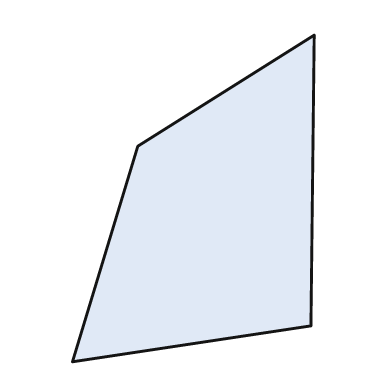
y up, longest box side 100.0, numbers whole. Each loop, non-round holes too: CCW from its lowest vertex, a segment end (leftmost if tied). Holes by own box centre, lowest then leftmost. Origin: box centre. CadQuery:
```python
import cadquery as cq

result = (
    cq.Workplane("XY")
    .moveTo(-37.0, -50.0)
    .lineTo(36.0, -39.0)
    .lineTo(37.0, 50.0)
    .lineTo(-17.0, 16.0)
    .close()
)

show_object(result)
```